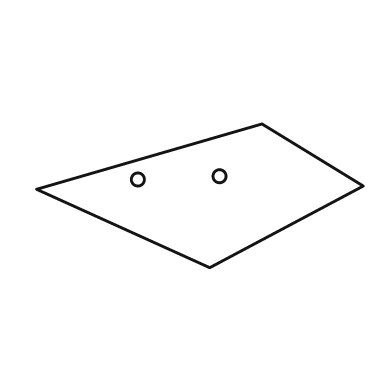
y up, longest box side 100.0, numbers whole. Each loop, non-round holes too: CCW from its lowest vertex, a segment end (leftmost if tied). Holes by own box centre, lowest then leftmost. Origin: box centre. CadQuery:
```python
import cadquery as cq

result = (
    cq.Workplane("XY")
    .moveTo(3.0, -22.0)
    .lineTo(50.0, 3.0)
    .lineTo(19.0, 22.0)
    .lineTo(-50.0, 2.0)
    .close()
    .moveTo(-19.0, 5.0)
    .circle(2.0)
    .moveTo(6.0, 6.0)
    .circle(2.0)
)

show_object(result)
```